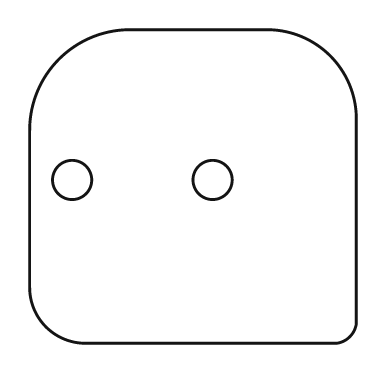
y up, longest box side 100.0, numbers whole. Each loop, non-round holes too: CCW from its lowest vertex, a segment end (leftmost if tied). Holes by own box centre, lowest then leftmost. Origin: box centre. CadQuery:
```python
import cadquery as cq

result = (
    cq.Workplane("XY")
    .moveTo(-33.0, -48.0)
    .lineTo(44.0, -48.0)
    .threePointArc((48.0, -46.0), (50.0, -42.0))
    .lineTo(50.0, 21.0)
    .threePointArc((42.0, 40.0), (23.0, 48.0))
    .lineTo(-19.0, 48.0)
    .threePointArc((-41.0, 39.0), (-50.0, 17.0))
    .lineTo(-50.0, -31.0)
    .threePointArc((-45.0, -43.0), (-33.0, -48.0))
    .close()
    .moveTo(-37.0, 2.0)
    .circle(6.0)
    .moveTo(6.0, 2.0)
    .circle(6.0)
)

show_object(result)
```